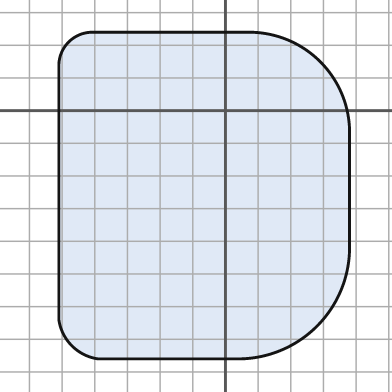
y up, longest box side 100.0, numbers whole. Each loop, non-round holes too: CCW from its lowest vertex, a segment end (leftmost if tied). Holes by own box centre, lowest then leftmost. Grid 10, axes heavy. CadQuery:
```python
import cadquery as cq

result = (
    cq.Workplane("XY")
    .moveTo(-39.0, -76.0)
    .lineTo(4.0, -76.0)
    .threePointArc((28.0, -66.0), (38.0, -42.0))
    .lineTo(38.0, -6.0)
    .threePointArc((29.0, 15.0), (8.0, 24.0))
    .lineTo(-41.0, 24.0)
    .threePointArc((-48.0, 21.0), (-51.0, 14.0))
    .lineTo(-51.0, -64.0)
    .threePointArc((-47.0, -72.0), (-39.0, -76.0))
    .close()
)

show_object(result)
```